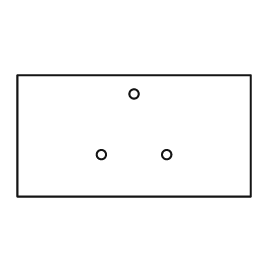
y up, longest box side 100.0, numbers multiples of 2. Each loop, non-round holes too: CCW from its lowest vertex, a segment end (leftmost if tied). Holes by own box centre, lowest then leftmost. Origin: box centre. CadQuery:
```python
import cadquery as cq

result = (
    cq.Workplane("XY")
    .moveTo(-50.0, -26.0)
    .lineTo(50.0, -26.0)
    .lineTo(50.0, 26.0)
    .lineTo(-50.0, 26.0)
    .close()
    .moveTo(-14.0, -8.0)
    .circle(2.0)
    .moveTo(14.0, -8.0)
    .circle(2.0)
    .moveTo(0.0, 18.0)
    .circle(2.0)
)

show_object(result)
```